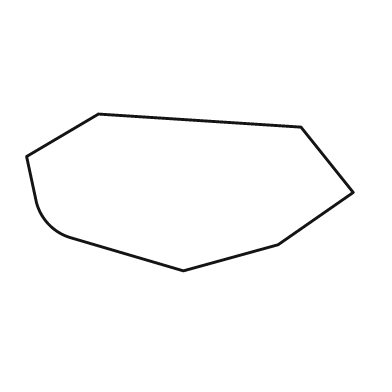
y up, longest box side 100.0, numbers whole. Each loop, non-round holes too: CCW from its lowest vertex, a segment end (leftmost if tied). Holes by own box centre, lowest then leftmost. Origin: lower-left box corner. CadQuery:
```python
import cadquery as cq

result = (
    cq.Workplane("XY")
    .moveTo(48.0, 0.0)
    .lineTo(77.0, 8.0)
    .lineTo(100.0, 24.0)
    .lineTo(84.0, 44.0)
    .lineTo(22.0, 48.0)
    .lineTo(0.0, 35.0)
    .lineTo(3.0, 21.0)
    .threePointArc((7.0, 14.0), (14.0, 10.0))
    .close()
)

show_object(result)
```